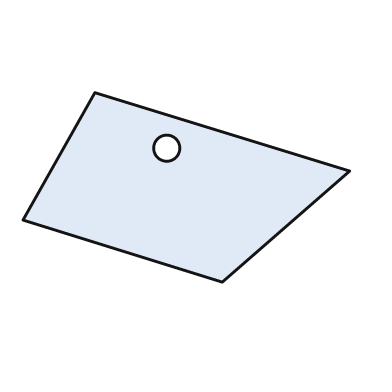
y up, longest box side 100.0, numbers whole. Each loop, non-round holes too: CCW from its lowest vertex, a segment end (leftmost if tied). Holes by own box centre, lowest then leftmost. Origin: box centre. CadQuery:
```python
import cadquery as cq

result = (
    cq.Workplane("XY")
    .moveTo(11.0, -29.0)
    .lineTo(50.0, 5.0)
    .lineTo(-28.0, 29.0)
    .lineTo(-50.0, -10.0)
    .close()
    .moveTo(-6.0, 12.0)
    .circle(4.0)
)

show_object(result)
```